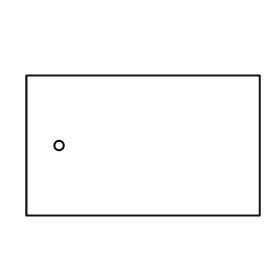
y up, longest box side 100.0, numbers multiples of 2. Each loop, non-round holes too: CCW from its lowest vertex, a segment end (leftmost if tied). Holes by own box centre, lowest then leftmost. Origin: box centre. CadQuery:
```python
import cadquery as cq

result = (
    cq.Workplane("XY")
    .moveTo(-50.0, -30.0)
    .lineTo(50.0, -30.0)
    .lineTo(50.0, 30.0)
    .lineTo(-50.0, 30.0)
    .close()
    .moveTo(-36.0, 0.0)
    .circle(2.0)
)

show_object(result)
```